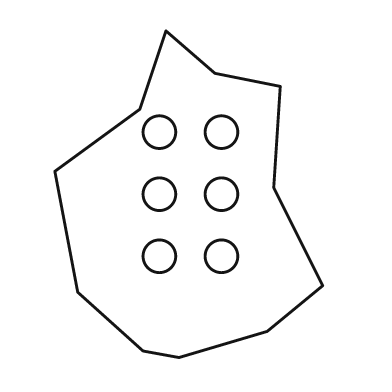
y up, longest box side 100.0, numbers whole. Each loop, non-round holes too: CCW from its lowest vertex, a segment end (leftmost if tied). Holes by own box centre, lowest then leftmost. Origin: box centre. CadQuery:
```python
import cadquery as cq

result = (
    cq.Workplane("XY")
    .moveTo(-3.0, -50.0)
    .lineTo(24.0, -42.0)
    .lineTo(41.0, -28.0)
    .lineTo(26.0, 2.0)
    .lineTo(28.0, 33.0)
    .lineTo(8.0, 37.0)
    .lineTo(-7.0, 50.0)
    .lineTo(-15.0, 26.0)
    .lineTo(-41.0, 7.0)
    .lineTo(-34.0, -30.0)
    .lineTo(-14.0, -48.0)
    .close()
    .moveTo(-9.0, -19.0)
    .circle(5.0)
    .moveTo(10.0, -19.0)
    .circle(5.0)
    .moveTo(-9.0, 0.0)
    .circle(5.0)
    .moveTo(10.0, 0.0)
    .circle(5.0)
    .moveTo(-9.0, 19.0)
    .circle(5.0)
    .moveTo(10.0, 19.0)
    .circle(5.0)
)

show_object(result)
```